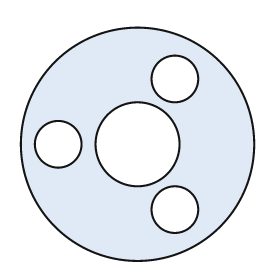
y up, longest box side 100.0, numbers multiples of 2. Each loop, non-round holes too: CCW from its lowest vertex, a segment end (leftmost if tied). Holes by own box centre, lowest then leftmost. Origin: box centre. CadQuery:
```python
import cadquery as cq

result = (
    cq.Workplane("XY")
    .moveTo(0.0, 0.0)
    .circle(50.0)
    .moveTo(16.0, -28.0)
    .circle(10.0)
    .moveTo(-34.0, 0.0)
    .circle(10.0)
    .moveTo(0.0, 0.0)
    .circle(18.0)
    .moveTo(16.0, 28.0)
    .circle(10.0)
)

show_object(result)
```